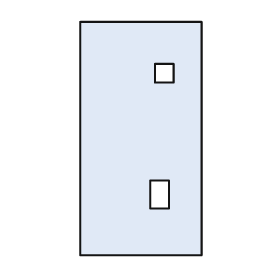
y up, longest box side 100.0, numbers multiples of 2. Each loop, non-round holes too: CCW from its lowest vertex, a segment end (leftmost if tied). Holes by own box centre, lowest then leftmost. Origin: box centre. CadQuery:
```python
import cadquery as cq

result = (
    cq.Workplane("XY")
    .moveTo(-26.0, -50.0)
    .lineTo(26.0, -50.0)
    .lineTo(26.0, 50.0)
    .lineTo(-26.0, 50.0)
    .close()
    .moveTo(4.0, -30.0)
    .lineTo(12.0, -30.0)
    .lineTo(12.0, -18.0)
    .lineTo(4.0, -18.0)
    .close()
    .moveTo(6.0, 24.0)
    .lineTo(14.0, 24.0)
    .lineTo(14.0, 32.0)
    .lineTo(6.0, 32.0)
    .close()
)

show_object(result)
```